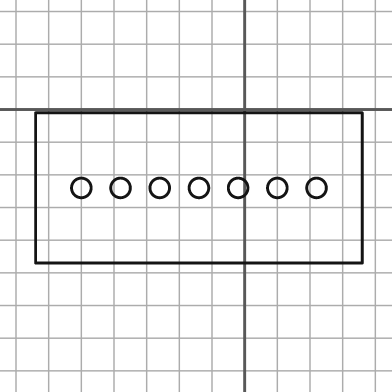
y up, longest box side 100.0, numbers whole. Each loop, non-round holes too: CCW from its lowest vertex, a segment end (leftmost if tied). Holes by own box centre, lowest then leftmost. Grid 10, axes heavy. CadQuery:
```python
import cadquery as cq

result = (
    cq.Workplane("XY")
    .moveTo(-64.0, -47.0)
    .lineTo(36.0, -47.0)
    .lineTo(36.0, -1.0)
    .lineTo(-64.0, -1.0)
    .close()
    .moveTo(-50.0, -24.0)
    .circle(3.0)
    .moveTo(-38.0, -24.0)
    .circle(3.0)
    .moveTo(-26.0, -24.0)
    .circle(3.0)
    .moveTo(-14.0, -24.0)
    .circle(3.0)
    .moveTo(-2.0, -24.0)
    .circle(3.0)
    .moveTo(10.0, -24.0)
    .circle(3.0)
    .moveTo(22.0, -24.0)
    .circle(3.0)
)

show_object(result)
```